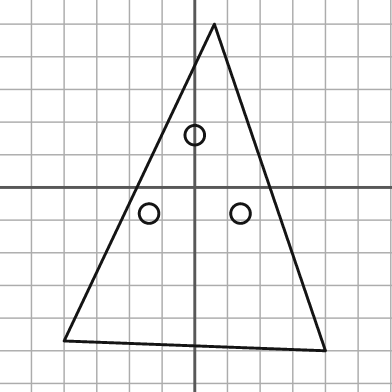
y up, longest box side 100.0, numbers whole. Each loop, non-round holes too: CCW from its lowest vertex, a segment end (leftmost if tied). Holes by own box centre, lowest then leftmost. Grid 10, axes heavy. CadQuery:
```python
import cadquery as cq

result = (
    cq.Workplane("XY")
    .moveTo(40.0, -50.0)
    .lineTo(6.0, 50.0)
    .lineTo(-40.0, -47.0)
    .close()
    .moveTo(-14.0, -8.0)
    .circle(3.0)
    .moveTo(14.0, -8.0)
    .circle(3.0)
    .moveTo(0.0, 16.0)
    .circle(3.0)
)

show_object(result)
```